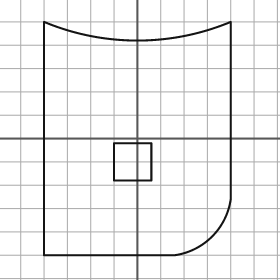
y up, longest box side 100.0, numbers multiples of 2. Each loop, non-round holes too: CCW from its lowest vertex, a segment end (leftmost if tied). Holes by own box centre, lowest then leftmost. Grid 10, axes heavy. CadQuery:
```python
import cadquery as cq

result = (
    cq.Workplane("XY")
    .moveTo(-40.0, -50.0)
    .lineTo(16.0, -50.0)
    .threePointArc((32.0, -42.0), (40.0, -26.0))
    .lineTo(40.0, 50.0)
    .threePointArc((0.0, 42.0), (-40.0, 50.0))
    .close()
    .moveTo(-10.0, -18.0)
    .lineTo(6.0, -18.0)
    .lineTo(6.0, -2.0)
    .lineTo(-10.0, -2.0)
    .close()
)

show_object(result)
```